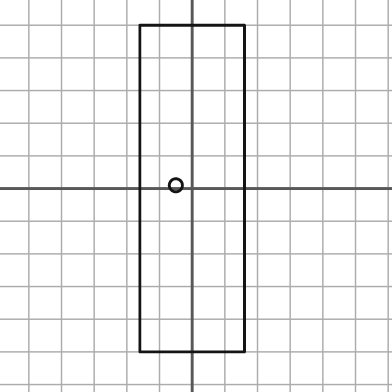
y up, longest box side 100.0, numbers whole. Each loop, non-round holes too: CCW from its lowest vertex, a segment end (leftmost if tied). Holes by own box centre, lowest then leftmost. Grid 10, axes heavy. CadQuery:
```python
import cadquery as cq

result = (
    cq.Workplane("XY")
    .moveTo(-16.0, -50.0)
    .lineTo(16.0, -50.0)
    .lineTo(16.0, 50.0)
    .lineTo(-16.0, 50.0)
    .close()
    .moveTo(-5.0, 1.0)
    .circle(2.0)
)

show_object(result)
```